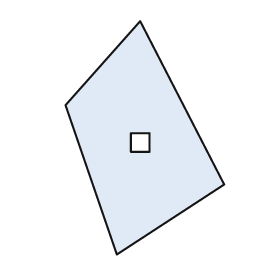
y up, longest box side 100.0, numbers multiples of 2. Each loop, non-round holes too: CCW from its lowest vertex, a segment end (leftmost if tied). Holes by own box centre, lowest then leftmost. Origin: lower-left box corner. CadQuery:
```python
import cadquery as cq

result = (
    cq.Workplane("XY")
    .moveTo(22.0, 0.0)
    .lineTo(68.0, 30.0)
    .lineTo(32.0, 100.0)
    .lineTo(0.0, 64.0)
    .close()
    .moveTo(28.0, 44.0)
    .lineTo(36.0, 44.0)
    .lineTo(36.0, 52.0)
    .lineTo(28.0, 52.0)
    .close()
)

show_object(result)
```